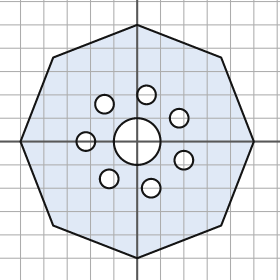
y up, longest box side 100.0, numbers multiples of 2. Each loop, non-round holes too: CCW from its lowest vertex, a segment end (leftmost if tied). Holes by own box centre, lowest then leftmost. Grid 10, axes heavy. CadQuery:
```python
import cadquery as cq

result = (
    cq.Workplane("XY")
    .moveTo(0.0, -50.0)
    .lineTo(36.0, -36.0)
    .lineTo(50.0, 0.0)
    .lineTo(36.0, 36.0)
    .lineTo(0.0, 50.0)
    .lineTo(-36.0, 36.0)
    .lineTo(-50.0, 0.0)
    .lineTo(-36.0, -36.0)
    .close()
    .moveTo(6.0, -20.0)
    .circle(4.0)
    .moveTo(-12.0, -16.0)
    .circle(4.0)
    .moveTo(20.0, -8.0)
    .circle(4.0)
    .moveTo(-22.0, 0.0)
    .circle(4.0)
    .moveTo(0.0, 0.0)
    .circle(10.0)
    .moveTo(18.0, 10.0)
    .circle(4.0)
    .moveTo(-14.0, 16.0)
    .circle(4.0)
    .moveTo(4.0, 20.0)
    .circle(4.0)
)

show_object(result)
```